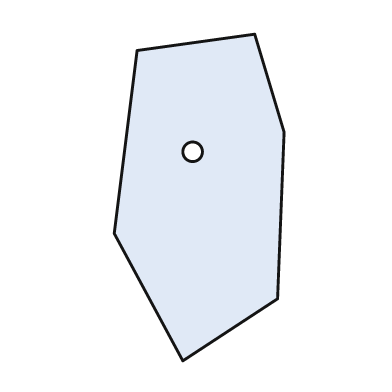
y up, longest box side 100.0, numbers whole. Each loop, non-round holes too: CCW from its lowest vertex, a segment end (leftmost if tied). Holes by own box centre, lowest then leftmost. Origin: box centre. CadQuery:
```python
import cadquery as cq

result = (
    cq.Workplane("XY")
    .moveTo(-5.0, -50.0)
    .lineTo(24.0, -31.0)
    .lineTo(26.0, 20.0)
    .lineTo(17.0, 50.0)
    .lineTo(-19.0, 45.0)
    .lineTo(-26.0, -11.0)
    .close()
    .moveTo(-2.0, 14.0)
    .circle(3.0)
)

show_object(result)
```